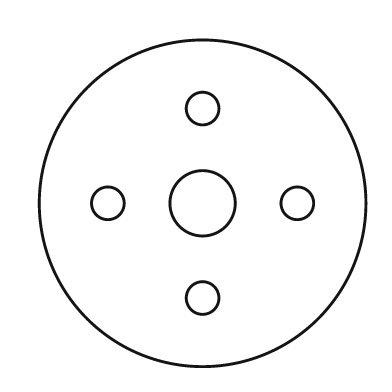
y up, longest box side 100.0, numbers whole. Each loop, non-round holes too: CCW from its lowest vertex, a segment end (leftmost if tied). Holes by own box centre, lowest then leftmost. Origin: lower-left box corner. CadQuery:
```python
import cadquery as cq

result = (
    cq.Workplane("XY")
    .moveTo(50.0, 50.0)
    .circle(50.0)
    .moveTo(50.0, 21.0)
    .circle(5.0)
    .moveTo(21.0, 50.0)
    .circle(5.0)
    .moveTo(50.0, 50.0)
    .circle(10.0)
    .moveTo(79.0, 50.0)
    .circle(5.0)
    .moveTo(50.0, 79.0)
    .circle(5.0)
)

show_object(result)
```